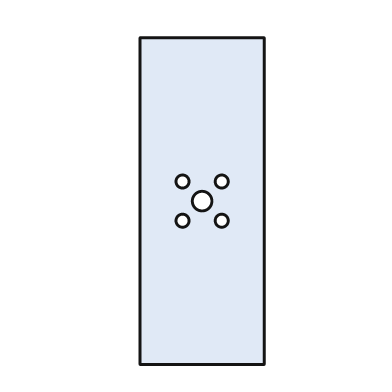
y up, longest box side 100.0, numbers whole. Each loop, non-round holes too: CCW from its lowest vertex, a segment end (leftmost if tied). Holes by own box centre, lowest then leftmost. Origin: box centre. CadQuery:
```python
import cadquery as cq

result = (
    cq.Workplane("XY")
    .moveTo(-19.0, -50.0)
    .lineTo(19.0, -50.0)
    .lineTo(19.0, 50.0)
    .lineTo(-19.0, 50.0)
    .close()
    .moveTo(-6.0, -6.0)
    .circle(2.0)
    .moveTo(6.0, -6.0)
    .circle(2.0)
    .moveTo(0.0, 0.0)
    .circle(3.0)
    .moveTo(-6.0, 6.0)
    .circle(2.0)
    .moveTo(6.0, 6.0)
    .circle(2.0)
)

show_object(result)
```